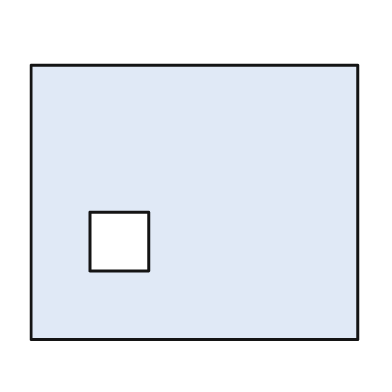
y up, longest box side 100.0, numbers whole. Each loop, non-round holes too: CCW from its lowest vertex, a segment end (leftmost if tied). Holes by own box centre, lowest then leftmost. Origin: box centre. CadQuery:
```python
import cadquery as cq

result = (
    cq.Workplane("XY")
    .moveTo(-50.0, -42.0)
    .lineTo(50.0, -42.0)
    .lineTo(50.0, 42.0)
    .lineTo(-50.0, 42.0)
    .close()
    .moveTo(-32.0, -21.0)
    .lineTo(-14.0, -21.0)
    .lineTo(-14.0, -3.0)
    .lineTo(-32.0, -3.0)
    .close()
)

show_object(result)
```